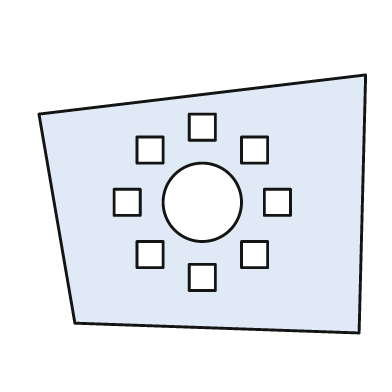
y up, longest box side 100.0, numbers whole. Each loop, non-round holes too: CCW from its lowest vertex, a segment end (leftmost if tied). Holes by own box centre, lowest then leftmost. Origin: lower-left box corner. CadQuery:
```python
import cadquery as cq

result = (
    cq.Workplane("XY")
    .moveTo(98.0, 0.0)
    .lineTo(100.0, 79.0)
    .lineTo(0.0, 67.0)
    .lineTo(11.0, 3.0)
    .close()
    .moveTo(46.0, 13.0)
    .lineTo(54.0, 13.0)
    .lineTo(54.0, 21.0)
    .lineTo(46.0, 21.0)
    .close()
    .moveTo(30.0, 20.0)
    .lineTo(38.0, 20.0)
    .lineTo(38.0, 28.0)
    .lineTo(30.0, 28.0)
    .close()
    .moveTo(62.0, 20.0)
    .lineTo(70.0, 20.0)
    .lineTo(70.0, 28.0)
    .lineTo(62.0, 28.0)
    .close()
    .moveTo(23.0, 36.0)
    .lineTo(31.0, 36.0)
    .lineTo(31.0, 44.0)
    .lineTo(23.0, 44.0)
    .close()
    .moveTo(50.0, 40.0)
    .circle(12.0)
    .moveTo(69.0, 36.0)
    .lineTo(77.0, 36.0)
    .lineTo(77.0, 44.0)
    .lineTo(69.0, 44.0)
    .close()
    .moveTo(30.0, 52.0)
    .lineTo(38.0, 52.0)
    .lineTo(38.0, 60.0)
    .lineTo(30.0, 60.0)
    .close()
    .moveTo(62.0, 52.0)
    .lineTo(70.0, 52.0)
    .lineTo(70.0, 60.0)
    .lineTo(62.0, 60.0)
    .close()
    .moveTo(46.0, 59.0)
    .lineTo(54.0, 59.0)
    .lineTo(54.0, 67.0)
    .lineTo(46.0, 67.0)
    .close()
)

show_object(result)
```